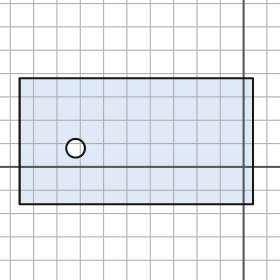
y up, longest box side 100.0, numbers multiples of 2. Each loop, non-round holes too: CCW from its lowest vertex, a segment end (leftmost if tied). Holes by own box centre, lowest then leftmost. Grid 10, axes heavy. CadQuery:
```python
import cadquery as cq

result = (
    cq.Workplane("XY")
    .moveTo(-96.0, -16.0)
    .lineTo(4.0, -16.0)
    .lineTo(4.0, 38.0)
    .lineTo(-96.0, 38.0)
    .close()
    .moveTo(-72.0, 8.0)
    .circle(4.0)
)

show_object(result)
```